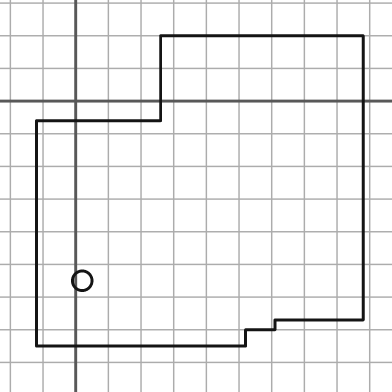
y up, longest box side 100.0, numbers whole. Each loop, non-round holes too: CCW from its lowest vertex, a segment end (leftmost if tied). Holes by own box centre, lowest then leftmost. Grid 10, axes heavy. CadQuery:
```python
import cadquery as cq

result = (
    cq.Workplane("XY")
    .moveTo(-12.0, -75.0)
    .lineTo(52.0, -75.0)
    .lineTo(52.0, -70.0)
    .lineTo(61.0, -70.0)
    .lineTo(61.0, -67.0)
    .lineTo(88.0, -67.0)
    .lineTo(88.0, 20.0)
    .lineTo(26.0, 20.0)
    .lineTo(26.0, -6.0)
    .lineTo(-12.0, -6.0)
    .close()
    .moveTo(2.0, -55.0)
    .circle(3.0)
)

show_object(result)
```